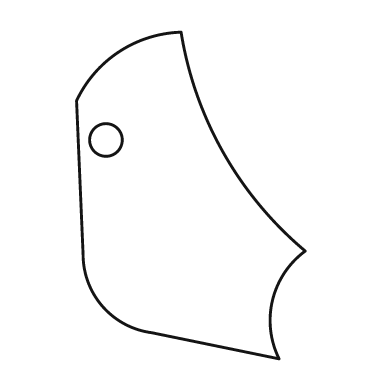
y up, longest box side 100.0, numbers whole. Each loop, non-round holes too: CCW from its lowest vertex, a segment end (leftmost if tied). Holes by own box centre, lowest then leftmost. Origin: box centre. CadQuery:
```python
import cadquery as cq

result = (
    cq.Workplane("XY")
    .moveTo(27.0, -50.0)
    .threePointArc((25.0, -32.0), (35.0, -17.0))
    .threePointArc((10.0, 13.0), (-3.0, 50.0))
    .threePointArc((-22.0, 44.0), (-35.0, 29.0))
    .lineTo(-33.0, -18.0)
    .threePointArc((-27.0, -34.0), (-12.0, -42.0))
    .close()
    .moveTo(-26.0, 17.0)
    .circle(5.0)
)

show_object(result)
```